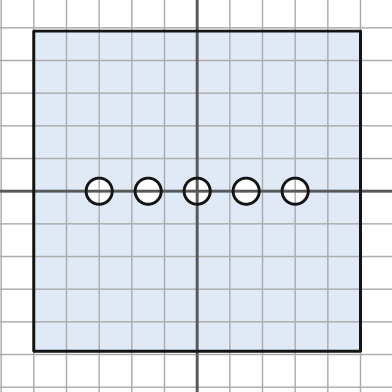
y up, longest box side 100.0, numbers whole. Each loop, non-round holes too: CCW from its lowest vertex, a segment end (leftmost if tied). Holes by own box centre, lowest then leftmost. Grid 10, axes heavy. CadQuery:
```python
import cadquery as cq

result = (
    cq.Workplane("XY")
    .moveTo(-50.0, -49.0)
    .lineTo(50.0, -49.0)
    .lineTo(50.0, 49.0)
    .lineTo(-50.0, 49.0)
    .close()
    .moveTo(-30.0, 0.0)
    .circle(4.0)
    .moveTo(-15.0, 0.0)
    .circle(4.0)
    .moveTo(0.0, 0.0)
    .circle(4.0)
    .moveTo(15.0, 0.0)
    .circle(4.0)
    .moveTo(30.0, 0.0)
    .circle(4.0)
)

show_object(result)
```